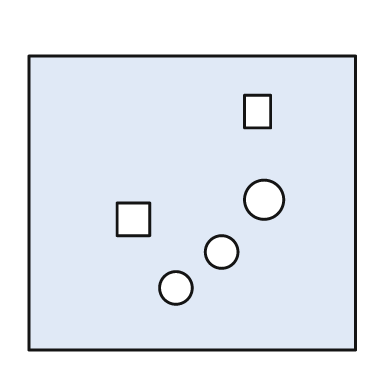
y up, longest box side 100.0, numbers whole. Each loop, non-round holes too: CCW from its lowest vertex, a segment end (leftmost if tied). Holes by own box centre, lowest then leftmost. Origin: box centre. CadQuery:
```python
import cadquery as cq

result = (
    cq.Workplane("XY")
    .moveTo(-50.0, -45.0)
    .lineTo(50.0, -45.0)
    .lineTo(50.0, 45.0)
    .lineTo(-50.0, 45.0)
    .close()
    .moveTo(-5.0, -26.0)
    .circle(5.0)
    .moveTo(9.0, -15.0)
    .circle(5.0)
    .moveTo(-23.0, -10.0)
    .lineTo(-13.0, -10.0)
    .lineTo(-13.0, 0.0)
    .lineTo(-23.0, 0.0)
    .close()
    .moveTo(22.0, 1.0)
    .circle(6.0)
    .moveTo(16.0, 23.0)
    .lineTo(24.0, 23.0)
    .lineTo(24.0, 33.0)
    .lineTo(16.0, 33.0)
    .close()
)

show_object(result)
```